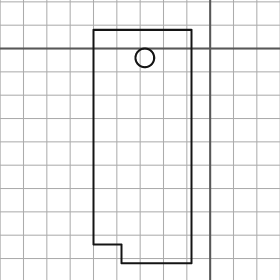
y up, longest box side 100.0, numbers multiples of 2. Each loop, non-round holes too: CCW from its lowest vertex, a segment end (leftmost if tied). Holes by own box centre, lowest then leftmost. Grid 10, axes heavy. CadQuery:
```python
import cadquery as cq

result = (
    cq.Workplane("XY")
    .moveTo(-38.0, -92.0)
    .lineTo(-8.0, -92.0)
    .lineTo(-8.0, 8.0)
    .lineTo(-50.0, 8.0)
    .lineTo(-50.0, -84.0)
    .lineTo(-38.0, -84.0)
    .close()
    .moveTo(-28.0, -4.0)
    .circle(4.0)
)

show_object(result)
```